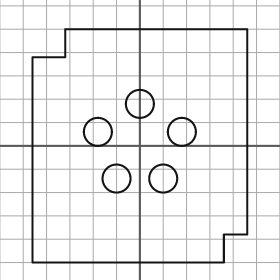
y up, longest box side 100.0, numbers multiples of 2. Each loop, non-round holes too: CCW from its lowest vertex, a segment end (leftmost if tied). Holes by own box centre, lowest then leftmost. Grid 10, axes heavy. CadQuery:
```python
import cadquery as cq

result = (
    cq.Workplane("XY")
    .moveTo(-46.0, -50.0)
    .lineTo(36.0, -50.0)
    .lineTo(36.0, -38.0)
    .lineTo(46.0, -38.0)
    .lineTo(46.0, 50.0)
    .lineTo(-32.0, 50.0)
    .lineTo(-32.0, 38.0)
    .lineTo(-46.0, 38.0)
    .close()
    .moveTo(-10.0, -14.0)
    .circle(6.0)
    .moveTo(10.0, -14.0)
    .circle(6.0)
    .moveTo(-18.0, 6.0)
    .circle(6.0)
    .moveTo(18.0, 6.0)
    .circle(6.0)
    .moveTo(0.0, 18.0)
    .circle(6.0)
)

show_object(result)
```